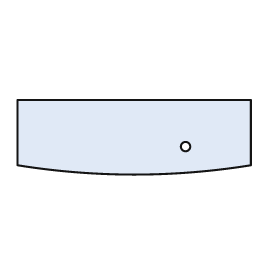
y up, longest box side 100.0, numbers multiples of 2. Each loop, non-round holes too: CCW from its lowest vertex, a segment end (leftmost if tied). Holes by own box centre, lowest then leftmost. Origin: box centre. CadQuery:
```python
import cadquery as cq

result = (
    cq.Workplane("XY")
    .moveTo(-50.0, -12.0)
    .threePointArc((0.0, -16.0), (50.0, -12.0))
    .lineTo(50.0, 16.0)
    .lineTo(-50.0, 16.0)
    .close()
    .moveTo(22.0, -4.0)
    .circle(2.0)
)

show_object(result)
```